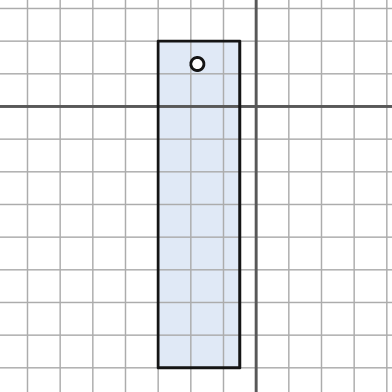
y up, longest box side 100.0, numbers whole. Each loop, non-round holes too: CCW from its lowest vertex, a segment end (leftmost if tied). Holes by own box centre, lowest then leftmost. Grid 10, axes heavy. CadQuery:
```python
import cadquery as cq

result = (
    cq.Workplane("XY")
    .moveTo(-30.0, -80.0)
    .lineTo(-5.0, -80.0)
    .lineTo(-5.0, 20.0)
    .lineTo(-30.0, 20.0)
    .close()
    .moveTo(-18.0, 13.0)
    .circle(2.0)
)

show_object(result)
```